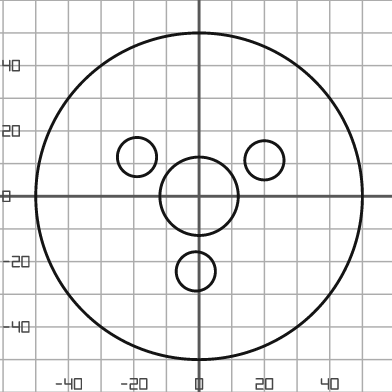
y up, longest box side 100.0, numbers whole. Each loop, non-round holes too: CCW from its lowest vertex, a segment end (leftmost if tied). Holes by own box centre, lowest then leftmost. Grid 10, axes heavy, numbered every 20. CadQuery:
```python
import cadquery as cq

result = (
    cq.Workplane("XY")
    .moveTo(0.0, 0.0)
    .circle(50.0)
    .moveTo(-1.0, -23.0)
    .circle(6.0)
    .moveTo(0.0, 0.0)
    .circle(12.0)
    .moveTo(20.0, 11.0)
    .circle(6.0)
    .moveTo(-19.0, 12.0)
    .circle(6.0)
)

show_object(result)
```